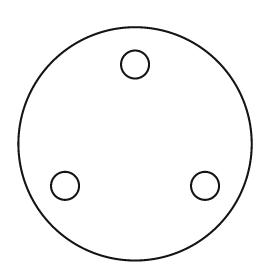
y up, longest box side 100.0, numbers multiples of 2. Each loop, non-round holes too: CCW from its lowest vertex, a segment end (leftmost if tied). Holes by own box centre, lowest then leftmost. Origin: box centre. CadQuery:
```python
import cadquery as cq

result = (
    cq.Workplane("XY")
    .moveTo(0.0, 0.0)
    .circle(50.0)
    .moveTo(-30.0, -18.0)
    .circle(6.0)
    .moveTo(30.0, -18.0)
    .circle(6.0)
    .moveTo(0.0, 34.0)
    .circle(6.0)
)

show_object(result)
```